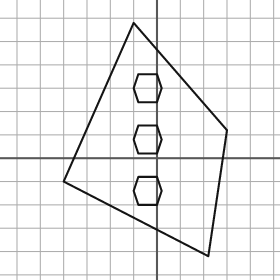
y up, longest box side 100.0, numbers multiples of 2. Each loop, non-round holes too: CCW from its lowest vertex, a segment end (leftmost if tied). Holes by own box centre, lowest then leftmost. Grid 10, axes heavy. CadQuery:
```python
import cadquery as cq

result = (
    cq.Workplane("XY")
    .moveTo(22.0, -42.0)
    .lineTo(30.0, 12.0)
    .lineTo(-10.0, 58.0)
    .lineTo(-40.0, -10.0)
    .close()
    .moveTo(-8.0, -20.0)
    .lineTo(0.0, -20.0)
    .lineTo(2.0, -14.0)
    .lineTo(0.0, -8.0)
    .lineTo(-8.0, -8.0)
    .lineTo(-10.0, -14.0)
    .close()
    .moveTo(-8.0, 2.0)
    .lineTo(0.0, 2.0)
    .lineTo(2.0, 8.0)
    .lineTo(0.0, 14.0)
    .lineTo(-8.0, 14.0)
    .lineTo(-10.0, 8.0)
    .close()
    .moveTo(-8.0, 24.0)
    .lineTo(0.0, 24.0)
    .lineTo(2.0, 30.0)
    .lineTo(0.0, 36.0)
    .lineTo(-8.0, 36.0)
    .lineTo(-10.0, 30.0)
    .close()
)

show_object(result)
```